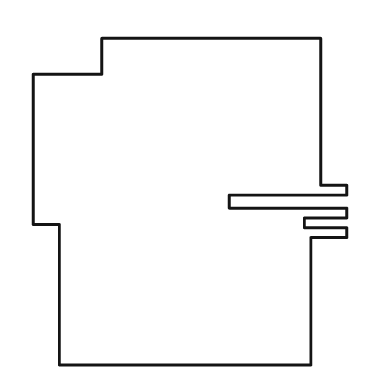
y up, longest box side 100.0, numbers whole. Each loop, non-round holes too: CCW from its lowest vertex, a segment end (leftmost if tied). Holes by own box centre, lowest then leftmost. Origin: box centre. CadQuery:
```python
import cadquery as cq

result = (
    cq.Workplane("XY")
    .moveTo(-40.0, -50.0)
    .lineTo(37.0, -50.0)
    .lineTo(37.0, -11.0)
    .lineTo(48.0, -11.0)
    .lineTo(48.0, -8.0)
    .lineTo(35.0, -8.0)
    .lineTo(35.0, -5.0)
    .lineTo(48.0, -5.0)
    .lineTo(48.0, -2.0)
    .lineTo(12.0, -2.0)
    .lineTo(12.0, 2.0)
    .lineTo(48.0, 2.0)
    .lineTo(48.0, 5.0)
    .lineTo(40.0, 5.0)
    .lineTo(40.0, 50.0)
    .lineTo(-27.0, 50.0)
    .lineTo(-27.0, 39.0)
    .lineTo(-48.0, 39.0)
    .lineTo(-48.0, -7.0)
    .lineTo(-40.0, -7.0)
    .close()
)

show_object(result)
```